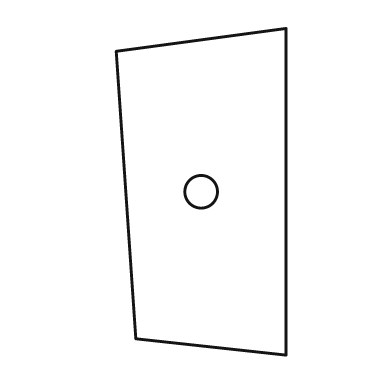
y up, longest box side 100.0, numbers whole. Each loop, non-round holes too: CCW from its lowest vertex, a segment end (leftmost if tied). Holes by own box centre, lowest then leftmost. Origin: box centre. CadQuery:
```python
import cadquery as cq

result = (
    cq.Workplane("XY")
    .moveTo(26.0, -50.0)
    .lineTo(26.0, 50.0)
    .lineTo(-26.0, 43.0)
    .lineTo(-20.0, -45.0)
    .close()
    .moveTo(0.0, 0.0)
    .circle(5.0)
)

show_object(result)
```